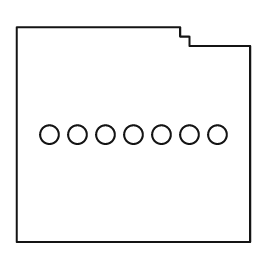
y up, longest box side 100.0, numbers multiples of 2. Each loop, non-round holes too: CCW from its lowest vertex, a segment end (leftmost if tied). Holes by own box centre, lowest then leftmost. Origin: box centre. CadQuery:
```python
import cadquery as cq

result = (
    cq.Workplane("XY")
    .moveTo(-50.0, -46.0)
    .lineTo(50.0, -46.0)
    .lineTo(50.0, 38.0)
    .lineTo(24.0, 38.0)
    .lineTo(24.0, 42.0)
    .lineTo(20.0, 42.0)
    .lineTo(20.0, 46.0)
    .lineTo(-50.0, 46.0)
    .close()
    .moveTo(-36.0, 0.0)
    .circle(4.0)
    .moveTo(-24.0, 0.0)
    .circle(4.0)
    .moveTo(-12.0, 0.0)
    .circle(4.0)
    .moveTo(0.0, 0.0)
    .circle(4.0)
    .moveTo(12.0, 0.0)
    .circle(4.0)
    .moveTo(24.0, 0.0)
    .circle(4.0)
    .moveTo(36.0, 0.0)
    .circle(4.0)
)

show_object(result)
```